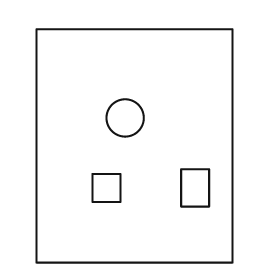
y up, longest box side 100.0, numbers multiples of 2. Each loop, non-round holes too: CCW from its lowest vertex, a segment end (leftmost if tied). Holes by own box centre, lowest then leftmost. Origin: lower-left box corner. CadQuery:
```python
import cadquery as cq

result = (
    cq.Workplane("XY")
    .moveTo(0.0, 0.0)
    .lineTo(84.0, 0.0)
    .lineTo(84.0, 100.0)
    .lineTo(0.0, 100.0)
    .close()
    .moveTo(24.0, 26.0)
    .lineTo(36.0, 26.0)
    .lineTo(36.0, 38.0)
    .lineTo(24.0, 38.0)
    .close()
    .moveTo(62.0, 24.0)
    .lineTo(74.0, 24.0)
    .lineTo(74.0, 40.0)
    .lineTo(62.0, 40.0)
    .close()
    .moveTo(38.0, 62.0)
    .circle(8.0)
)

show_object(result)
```